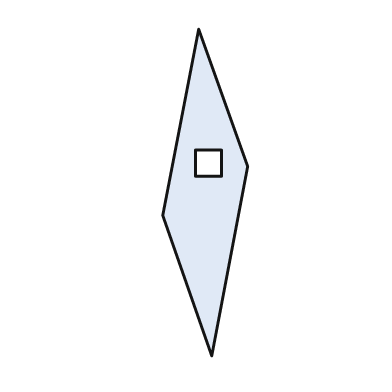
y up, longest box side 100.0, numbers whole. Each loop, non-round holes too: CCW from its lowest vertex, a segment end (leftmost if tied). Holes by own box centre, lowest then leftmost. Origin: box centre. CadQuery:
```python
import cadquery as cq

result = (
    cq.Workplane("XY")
    .moveTo(2.0, -50.0)
    .lineTo(13.0, 8.0)
    .lineTo(-2.0, 50.0)
    .lineTo(-13.0, -7.0)
    .close()
    .moveTo(-3.0, 5.0)
    .lineTo(5.0, 5.0)
    .lineTo(5.0, 13.0)
    .lineTo(-3.0, 13.0)
    .close()
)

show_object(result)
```